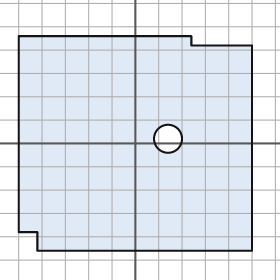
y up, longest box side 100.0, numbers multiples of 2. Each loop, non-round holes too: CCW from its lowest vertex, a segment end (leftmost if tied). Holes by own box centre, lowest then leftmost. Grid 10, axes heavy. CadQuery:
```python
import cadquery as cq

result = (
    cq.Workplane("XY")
    .moveTo(-42.0, -46.0)
    .lineTo(50.0, -46.0)
    .lineTo(50.0, 42.0)
    .lineTo(24.0, 42.0)
    .lineTo(24.0, 46.0)
    .lineTo(-50.0, 46.0)
    .lineTo(-50.0, -38.0)
    .lineTo(-42.0, -38.0)
    .close()
    .moveTo(14.0, 2.0)
    .circle(6.0)
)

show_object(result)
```